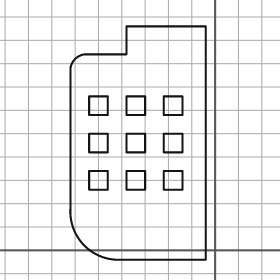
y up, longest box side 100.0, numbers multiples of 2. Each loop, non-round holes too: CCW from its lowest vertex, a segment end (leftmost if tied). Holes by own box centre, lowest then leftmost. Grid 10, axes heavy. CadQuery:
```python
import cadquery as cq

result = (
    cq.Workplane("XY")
    .moveTo(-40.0, -4.0)
    .lineTo(-4.0, -4.0)
    .lineTo(-4.0, 96.0)
    .lineTo(-38.0, 96.0)
    .lineTo(-38.0, 84.0)
    .lineTo(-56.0, 84.0)
    .threePointArc((-60.0, 82.0), (-62.0, 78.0))
    .lineTo(-62.0, 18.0)
    .threePointArc((-56.0, 2.0), (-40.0, -4.0))
    .close()
    .moveTo(-54.0, 26.0)
    .lineTo(-46.0, 26.0)
    .lineTo(-46.0, 34.0)
    .lineTo(-54.0, 34.0)
    .close()
    .moveTo(-38.0, 26.0)
    .lineTo(-30.0, 26.0)
    .lineTo(-30.0, 34.0)
    .lineTo(-38.0, 34.0)
    .close()
    .moveTo(-22.0, 26.0)
    .lineTo(-14.0, 26.0)
    .lineTo(-14.0, 34.0)
    .lineTo(-22.0, 34.0)
    .close()
    .moveTo(-54.0, 42.0)
    .lineTo(-46.0, 42.0)
    .lineTo(-46.0, 50.0)
    .lineTo(-54.0, 50.0)
    .close()
    .moveTo(-38.0, 42.0)
    .lineTo(-30.0, 42.0)
    .lineTo(-30.0, 50.0)
    .lineTo(-38.0, 50.0)
    .close()
    .moveTo(-22.0, 42.0)
    .lineTo(-14.0, 42.0)
    .lineTo(-14.0, 50.0)
    .lineTo(-22.0, 50.0)
    .close()
    .moveTo(-54.0, 58.0)
    .lineTo(-46.0, 58.0)
    .lineTo(-46.0, 66.0)
    .lineTo(-54.0, 66.0)
    .close()
    .moveTo(-38.0, 58.0)
    .lineTo(-30.0, 58.0)
    .lineTo(-30.0, 66.0)
    .lineTo(-38.0, 66.0)
    .close()
    .moveTo(-22.0, 58.0)
    .lineTo(-14.0, 58.0)
    .lineTo(-14.0, 66.0)
    .lineTo(-22.0, 66.0)
    .close()
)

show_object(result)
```